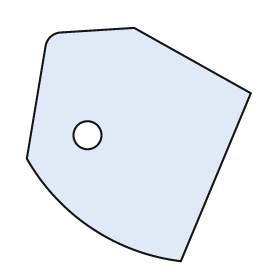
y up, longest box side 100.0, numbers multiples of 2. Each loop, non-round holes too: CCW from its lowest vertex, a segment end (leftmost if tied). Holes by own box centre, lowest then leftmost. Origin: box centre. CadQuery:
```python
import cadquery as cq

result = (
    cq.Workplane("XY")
    .moveTo(18.0, -50.0)
    .lineTo(48.0, 22.0)
    .lineTo(-2.0, 50.0)
    .lineTo(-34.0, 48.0)
    .threePointArc((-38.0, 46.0), (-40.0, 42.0))
    .lineTo(-48.0, -6.0)
    .threePointArc((-20.0, -36.0), (18.0, -50.0))
    .close()
    .moveTo(-22.0, 4.0)
    .circle(6.0)
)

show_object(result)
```